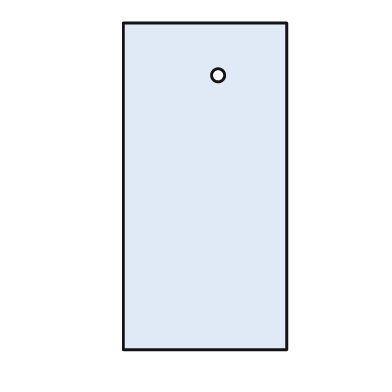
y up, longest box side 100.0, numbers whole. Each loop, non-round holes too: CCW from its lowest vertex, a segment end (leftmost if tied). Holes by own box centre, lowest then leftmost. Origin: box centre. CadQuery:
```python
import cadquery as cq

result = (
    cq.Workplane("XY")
    .moveTo(-25.0, -50.0)
    .lineTo(25.0, -50.0)
    .lineTo(25.0, 50.0)
    .lineTo(-25.0, 50.0)
    .close()
    .moveTo(4.0, 34.0)
    .circle(2.0)
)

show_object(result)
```